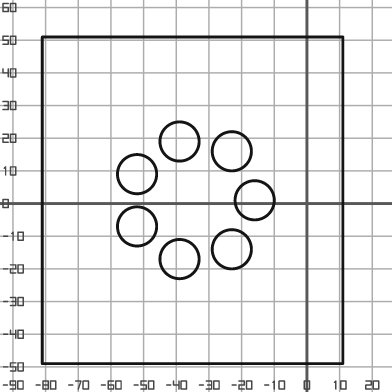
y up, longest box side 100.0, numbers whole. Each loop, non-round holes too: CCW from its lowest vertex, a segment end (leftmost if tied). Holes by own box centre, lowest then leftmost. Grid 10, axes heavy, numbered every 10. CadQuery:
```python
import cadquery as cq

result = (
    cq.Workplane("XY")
    .moveTo(-81.0, -49.0)
    .lineTo(11.0, -49.0)
    .lineTo(11.0, 51.0)
    .lineTo(-81.0, 51.0)
    .close()
    .moveTo(-39.0, -17.0)
    .circle(6.0)
    .moveTo(-23.0, -14.0)
    .circle(6.0)
    .moveTo(-52.0, -7.0)
    .circle(6.0)
    .moveTo(-16.0, 1.0)
    .circle(6.0)
    .moveTo(-52.0, 9.0)
    .circle(6.0)
    .moveTo(-23.0, 16.0)
    .circle(6.0)
    .moveTo(-39.0, 19.0)
    .circle(6.0)
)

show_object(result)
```